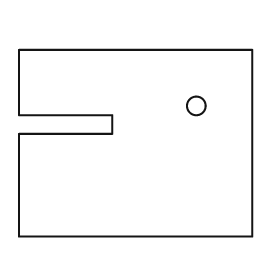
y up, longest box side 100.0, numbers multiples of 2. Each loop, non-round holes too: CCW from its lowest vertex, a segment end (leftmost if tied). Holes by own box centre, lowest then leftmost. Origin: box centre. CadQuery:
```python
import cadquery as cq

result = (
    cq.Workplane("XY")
    .moveTo(-50.0, -40.0)
    .lineTo(50.0, -40.0)
    .lineTo(50.0, 40.0)
    .lineTo(-50.0, 40.0)
    .lineTo(-50.0, 12.0)
    .lineTo(-10.0, 12.0)
    .lineTo(-10.0, 4.0)
    .lineTo(-50.0, 4.0)
    .close()
    .moveTo(26.0, 16.0)
    .circle(4.0)
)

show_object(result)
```